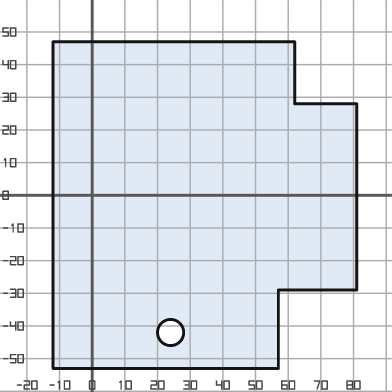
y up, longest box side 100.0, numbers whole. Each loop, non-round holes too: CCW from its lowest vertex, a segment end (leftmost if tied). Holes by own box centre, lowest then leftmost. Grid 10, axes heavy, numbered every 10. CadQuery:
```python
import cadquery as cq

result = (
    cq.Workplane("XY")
    .moveTo(-12.0, -53.0)
    .lineTo(57.0, -53.0)
    .lineTo(57.0, -29.0)
    .lineTo(81.0, -29.0)
    .lineTo(81.0, 28.0)
    .lineTo(62.0, 28.0)
    .lineTo(62.0, 47.0)
    .lineTo(-12.0, 47.0)
    .close()
    .moveTo(24.0, -42.0)
    .circle(4.0)
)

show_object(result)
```